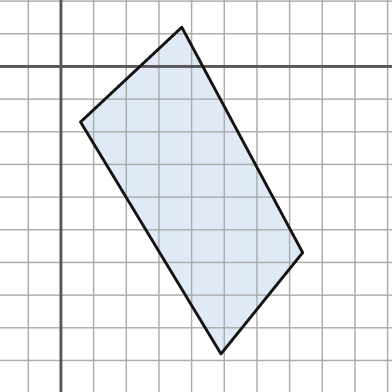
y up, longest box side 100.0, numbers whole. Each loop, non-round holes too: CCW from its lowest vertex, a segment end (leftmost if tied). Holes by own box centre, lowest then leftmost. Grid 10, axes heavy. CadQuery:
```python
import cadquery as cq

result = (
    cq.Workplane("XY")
    .moveTo(49.0, -88.0)
    .lineTo(74.0, -57.0)
    .lineTo(37.0, 12.0)
    .lineTo(6.0, -17.0)
    .close()
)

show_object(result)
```